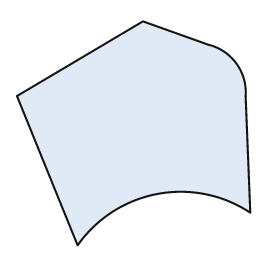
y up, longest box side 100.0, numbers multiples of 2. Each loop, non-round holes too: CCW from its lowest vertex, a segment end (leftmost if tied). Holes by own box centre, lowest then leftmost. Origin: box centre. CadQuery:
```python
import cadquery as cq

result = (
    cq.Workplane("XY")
    .moveTo(-24.0, -48.0)
    .threePointArc((10.0, -26.0), (50.0, -34.0))
    .lineTo(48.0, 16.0)
    .threePointArc((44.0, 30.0), (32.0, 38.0))
    .lineTo(4.0, 48.0)
    .lineTo(-50.0, 16.0)
    .close()
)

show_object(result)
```